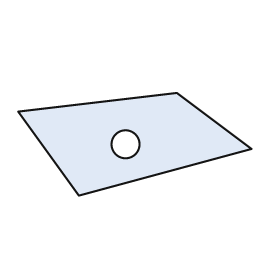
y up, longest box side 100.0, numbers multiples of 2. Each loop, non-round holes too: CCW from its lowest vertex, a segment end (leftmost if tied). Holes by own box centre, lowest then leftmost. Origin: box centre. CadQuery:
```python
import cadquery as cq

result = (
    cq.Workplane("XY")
    .moveTo(-24.0, -22.0)
    .lineTo(50.0, -2.0)
    .lineTo(18.0, 22.0)
    .lineTo(-50.0, 14.0)
    .close()
    .moveTo(-4.0, 0.0)
    .circle(6.0)
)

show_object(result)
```